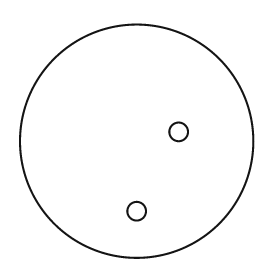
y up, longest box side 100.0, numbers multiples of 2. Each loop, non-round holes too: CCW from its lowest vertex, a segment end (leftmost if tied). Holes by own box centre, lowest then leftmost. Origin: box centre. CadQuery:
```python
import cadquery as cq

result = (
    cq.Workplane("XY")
    .moveTo(0.0, 0.0)
    .circle(50.0)
    .moveTo(0.0, -30.0)
    .circle(4.0)
    .moveTo(18.0, 4.0)
    .circle(4.0)
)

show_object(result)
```